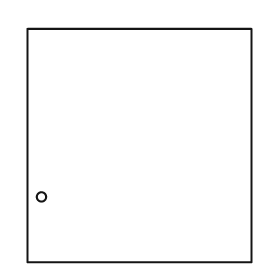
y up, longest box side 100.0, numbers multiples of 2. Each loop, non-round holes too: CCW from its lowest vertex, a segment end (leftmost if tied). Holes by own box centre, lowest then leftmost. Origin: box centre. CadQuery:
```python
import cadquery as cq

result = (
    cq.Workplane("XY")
    .moveTo(-48.0, -50.0)
    .lineTo(48.0, -50.0)
    .lineTo(48.0, 50.0)
    .lineTo(-48.0, 50.0)
    .close()
    .moveTo(-42.0, -22.0)
    .circle(2.0)
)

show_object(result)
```